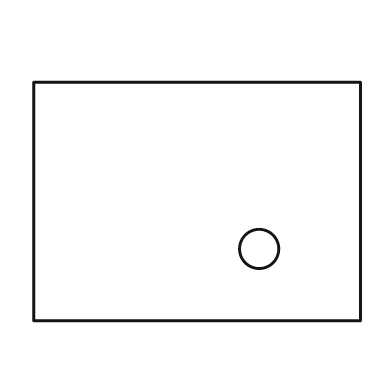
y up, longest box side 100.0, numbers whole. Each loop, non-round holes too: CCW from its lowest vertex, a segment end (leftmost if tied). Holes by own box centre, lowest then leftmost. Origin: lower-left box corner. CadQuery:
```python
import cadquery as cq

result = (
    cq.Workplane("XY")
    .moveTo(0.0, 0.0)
    .lineTo(100.0, 0.0)
    .lineTo(100.0, 73.0)
    .lineTo(0.0, 73.0)
    .close()
    .moveTo(69.0, 22.0)
    .circle(6.0)
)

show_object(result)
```